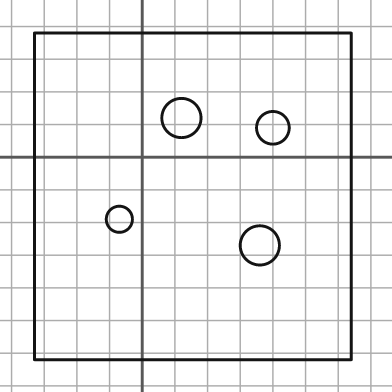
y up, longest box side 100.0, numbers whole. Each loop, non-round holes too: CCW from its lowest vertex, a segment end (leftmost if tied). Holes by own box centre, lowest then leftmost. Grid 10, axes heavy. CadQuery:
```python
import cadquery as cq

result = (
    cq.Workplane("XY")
    .moveTo(-33.0, -62.0)
    .lineTo(64.0, -62.0)
    .lineTo(64.0, 38.0)
    .lineTo(-33.0, 38.0)
    .close()
    .moveTo(36.0, -27.0)
    .circle(6.0)
    .moveTo(-7.0, -19.0)
    .circle(4.0)
    .moveTo(40.0, 9.0)
    .circle(5.0)
    .moveTo(12.0, 12.0)
    .circle(6.0)
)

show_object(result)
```